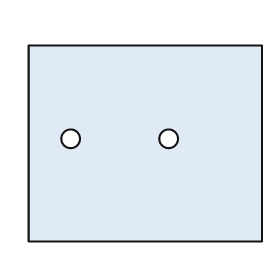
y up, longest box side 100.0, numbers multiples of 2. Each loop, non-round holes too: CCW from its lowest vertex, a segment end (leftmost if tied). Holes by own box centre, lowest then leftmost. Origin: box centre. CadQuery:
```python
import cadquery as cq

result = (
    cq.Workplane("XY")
    .moveTo(-50.0, -42.0)
    .lineTo(50.0, -42.0)
    .lineTo(50.0, 42.0)
    .lineTo(-50.0, 42.0)
    .close()
    .moveTo(-32.0, 2.0)
    .circle(4.0)
    .moveTo(10.0, 2.0)
    .circle(4.0)
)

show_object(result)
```